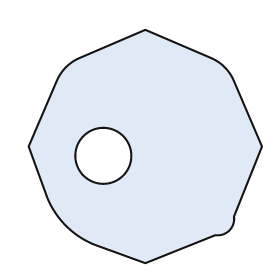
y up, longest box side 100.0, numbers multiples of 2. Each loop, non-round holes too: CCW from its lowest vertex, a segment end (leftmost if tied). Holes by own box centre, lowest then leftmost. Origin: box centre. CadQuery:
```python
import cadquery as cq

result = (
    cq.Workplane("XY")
    .moveTo(0.0, -50.0)
    .lineTo(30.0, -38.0)
    .threePointArc((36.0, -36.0), (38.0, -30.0))
    .lineTo(50.0, 0.0)
    .lineTo(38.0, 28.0)
    .threePointArc((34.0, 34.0), (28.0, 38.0))
    .lineTo(0.0, 50.0)
    .lineTo(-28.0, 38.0)
    .threePointArc((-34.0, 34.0), (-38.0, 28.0))
    .lineTo(-50.0, 0.0)
    .lineTo(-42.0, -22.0)
    .threePointArc((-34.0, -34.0), (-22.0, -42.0))
    .close()
    .moveTo(-18.0, -4.0)
    .circle(12.0)
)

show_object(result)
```